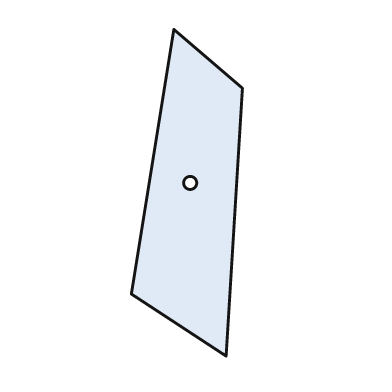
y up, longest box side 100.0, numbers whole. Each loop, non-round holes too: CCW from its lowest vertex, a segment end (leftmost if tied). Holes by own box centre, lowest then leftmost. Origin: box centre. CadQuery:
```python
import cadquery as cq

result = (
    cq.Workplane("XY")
    .moveTo(12.0, -50.0)
    .lineTo(17.0, 32.0)
    .lineTo(-4.0, 50.0)
    .lineTo(-17.0, -31.0)
    .close()
    .moveTo(1.0, 3.0)
    .circle(2.0)
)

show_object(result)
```